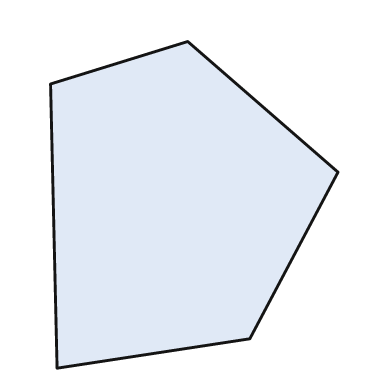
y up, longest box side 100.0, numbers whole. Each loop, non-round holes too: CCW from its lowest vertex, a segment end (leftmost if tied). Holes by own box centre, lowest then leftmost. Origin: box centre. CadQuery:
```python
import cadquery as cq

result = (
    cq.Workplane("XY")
    .moveTo(-42.0, -50.0)
    .lineTo(17.0, -41.0)
    .lineTo(44.0, 10.0)
    .lineTo(-2.0, 50.0)
    .lineTo(-44.0, 37.0)
    .close()
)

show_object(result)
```